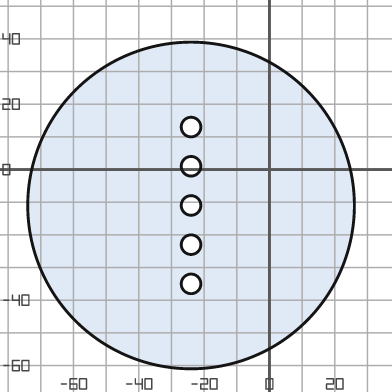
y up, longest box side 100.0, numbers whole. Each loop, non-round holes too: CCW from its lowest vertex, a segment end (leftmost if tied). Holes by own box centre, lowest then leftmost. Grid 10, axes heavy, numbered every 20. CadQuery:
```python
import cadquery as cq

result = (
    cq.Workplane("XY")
    .moveTo(-24.0, -11.0)
    .circle(50.0)
    .moveTo(-24.0, -35.0)
    .circle(3.0)
    .moveTo(-24.0, -23.0)
    .circle(3.0)
    .moveTo(-24.0, -11.0)
    .circle(3.0)
    .moveTo(-24.0, 1.0)
    .circle(3.0)
    .moveTo(-24.0, 13.0)
    .circle(3.0)
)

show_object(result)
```